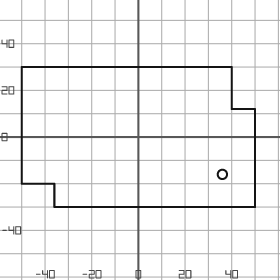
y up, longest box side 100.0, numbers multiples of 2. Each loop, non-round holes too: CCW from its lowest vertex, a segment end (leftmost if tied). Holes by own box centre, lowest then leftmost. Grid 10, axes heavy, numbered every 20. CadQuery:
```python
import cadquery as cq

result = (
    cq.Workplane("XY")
    .moveTo(-36.0, -30.0)
    .lineTo(50.0, -30.0)
    .lineTo(50.0, 12.0)
    .lineTo(40.0, 12.0)
    .lineTo(40.0, 30.0)
    .lineTo(-50.0, 30.0)
    .lineTo(-50.0, -20.0)
    .lineTo(-36.0, -20.0)
    .close()
    .moveTo(36.0, -16.0)
    .circle(2.0)
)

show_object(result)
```